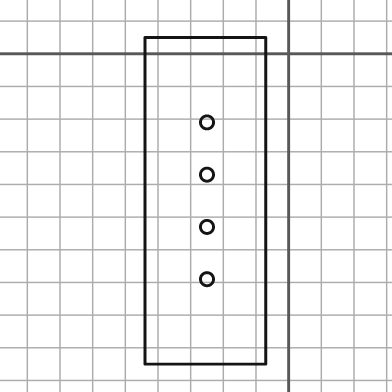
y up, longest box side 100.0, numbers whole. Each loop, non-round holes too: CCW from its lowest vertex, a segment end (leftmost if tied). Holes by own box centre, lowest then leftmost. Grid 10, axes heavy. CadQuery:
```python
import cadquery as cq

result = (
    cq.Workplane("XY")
    .moveTo(-44.0, -95.0)
    .lineTo(-7.0, -95.0)
    .lineTo(-7.0, 5.0)
    .lineTo(-44.0, 5.0)
    .close()
    .moveTo(-25.0, -69.0)
    .circle(2.0)
    .moveTo(-25.0, -53.0)
    .circle(2.0)
    .moveTo(-25.0, -37.0)
    .circle(2.0)
    .moveTo(-25.0, -21.0)
    .circle(2.0)
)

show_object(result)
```